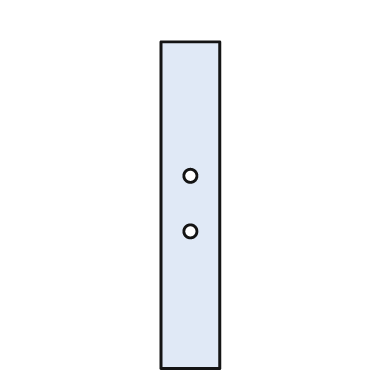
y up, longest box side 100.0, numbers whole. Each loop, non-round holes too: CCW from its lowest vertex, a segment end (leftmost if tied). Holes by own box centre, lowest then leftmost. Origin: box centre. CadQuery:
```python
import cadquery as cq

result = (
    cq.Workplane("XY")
    .moveTo(-9.0, -50.0)
    .lineTo(9.0, -50.0)
    .lineTo(9.0, 50.0)
    .lineTo(-9.0, 50.0)
    .close()
    .moveTo(0.0, -8.0)
    .circle(2.0)
    .moveTo(0.0, 9.0)
    .circle(2.0)
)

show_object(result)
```